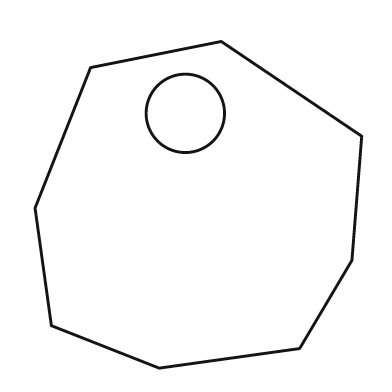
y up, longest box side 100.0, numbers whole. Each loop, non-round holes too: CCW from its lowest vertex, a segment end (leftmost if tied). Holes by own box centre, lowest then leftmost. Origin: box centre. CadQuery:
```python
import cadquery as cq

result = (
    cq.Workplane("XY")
    .moveTo(-12.0, -50.0)
    .lineTo(31.0, -44.0)
    .lineTo(47.0, -17.0)
    .lineTo(50.0, 21.0)
    .lineTo(7.0, 50.0)
    .lineTo(-33.0, 42.0)
    .lineTo(-50.0, -1.0)
    .lineTo(-45.0, -37.0)
    .close()
    .moveTo(-4.0, 28.0)
    .circle(12.0)
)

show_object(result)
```